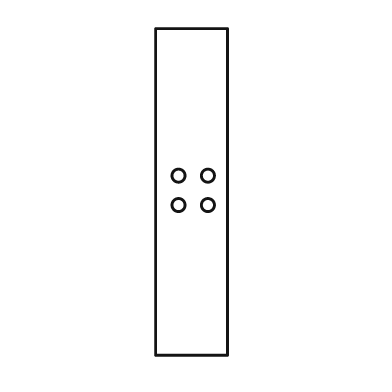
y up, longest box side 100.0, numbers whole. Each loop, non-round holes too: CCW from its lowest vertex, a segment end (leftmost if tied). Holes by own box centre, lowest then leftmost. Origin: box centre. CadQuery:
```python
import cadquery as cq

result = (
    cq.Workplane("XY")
    .moveTo(-11.0, -50.0)
    .lineTo(11.0, -50.0)
    .lineTo(11.0, 50.0)
    .lineTo(-11.0, 50.0)
    .close()
    .moveTo(-4.0, -4.0)
    .circle(2.0)
    .moveTo(5.0, -4.0)
    .circle(2.0)
    .moveTo(-4.0, 5.0)
    .circle(2.0)
    .moveTo(5.0, 5.0)
    .circle(2.0)
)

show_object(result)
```